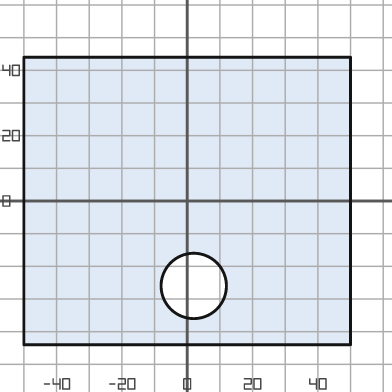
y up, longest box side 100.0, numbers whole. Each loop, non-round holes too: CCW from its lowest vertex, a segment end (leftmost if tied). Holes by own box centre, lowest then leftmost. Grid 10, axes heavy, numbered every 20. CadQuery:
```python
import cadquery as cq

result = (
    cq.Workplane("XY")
    .moveTo(-50.0, -44.0)
    .lineTo(50.0, -44.0)
    .lineTo(50.0, 44.0)
    .lineTo(-50.0, 44.0)
    .close()
    .moveTo(2.0, -26.0)
    .circle(10.0)
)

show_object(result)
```